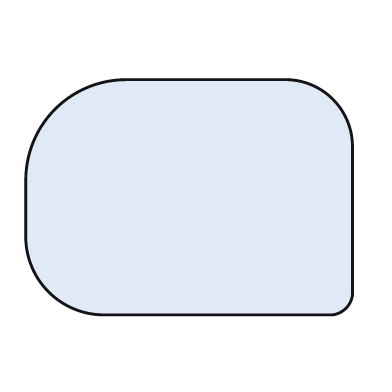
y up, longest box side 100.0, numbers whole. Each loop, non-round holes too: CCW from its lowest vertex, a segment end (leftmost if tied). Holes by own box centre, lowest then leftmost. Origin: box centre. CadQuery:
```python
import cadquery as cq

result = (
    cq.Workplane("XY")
    .moveTo(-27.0, -36.0)
    .lineTo(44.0, -36.0)
    .threePointArc((48.0, -34.0), (50.0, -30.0))
    .lineTo(50.0, 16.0)
    .threePointArc((44.0, 30.0), (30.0, 36.0))
    .lineTo(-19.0, 36.0)
    .threePointArc((-41.0, 27.0), (-50.0, 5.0))
    .lineTo(-50.0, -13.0)
    .threePointArc((-43.0, -29.0), (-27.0, -36.0))
    .close()
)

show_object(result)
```